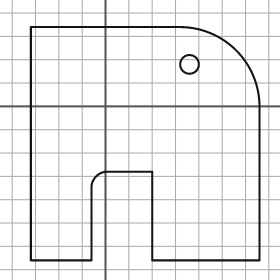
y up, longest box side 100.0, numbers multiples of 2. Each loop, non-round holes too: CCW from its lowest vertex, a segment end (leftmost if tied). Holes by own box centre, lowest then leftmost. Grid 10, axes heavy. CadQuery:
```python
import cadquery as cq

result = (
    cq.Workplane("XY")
    .moveTo(-32.0, -66.0)
    .lineTo(-6.0, -66.0)
    .lineTo(-6.0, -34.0)
    .threePointArc((-4.0, -30.0), (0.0, -28.0))
    .lineTo(20.0, -28.0)
    .lineTo(20.0, -66.0)
    .lineTo(66.0, -66.0)
    .lineTo(66.0, 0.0)
    .threePointArc((56.0, 24.0), (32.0, 34.0))
    .lineTo(-32.0, 34.0)
    .close()
    .moveTo(36.0, 18.0)
    .circle(4.0)
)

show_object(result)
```